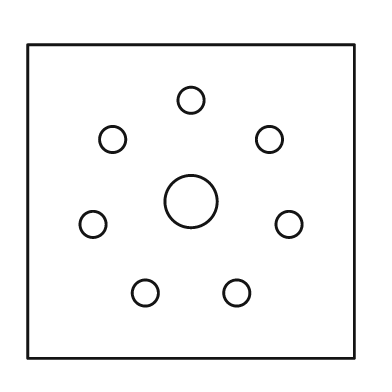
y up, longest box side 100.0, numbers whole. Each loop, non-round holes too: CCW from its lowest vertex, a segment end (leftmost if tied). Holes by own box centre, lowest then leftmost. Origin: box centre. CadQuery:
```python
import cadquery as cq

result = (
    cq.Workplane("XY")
    .moveTo(-50.0, -48.0)
    .lineTo(50.0, -48.0)
    .lineTo(50.0, 48.0)
    .lineTo(-50.0, 48.0)
    .close()
    .moveTo(-14.0, -28.0)
    .circle(4.0)
    .moveTo(14.0, -28.0)
    .circle(4.0)
    .moveTo(-30.0, -7.0)
    .circle(4.0)
    .moveTo(30.0, -7.0)
    .circle(4.0)
    .moveTo(0.0, 0.0)
    .circle(8.0)
    .moveTo(-24.0, 19.0)
    .circle(4.0)
    .moveTo(24.0, 19.0)
    .circle(4.0)
    .moveTo(0.0, 31.0)
    .circle(4.0)
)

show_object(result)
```